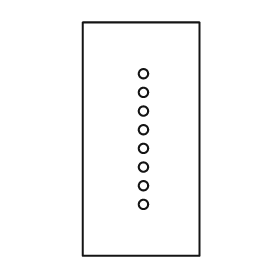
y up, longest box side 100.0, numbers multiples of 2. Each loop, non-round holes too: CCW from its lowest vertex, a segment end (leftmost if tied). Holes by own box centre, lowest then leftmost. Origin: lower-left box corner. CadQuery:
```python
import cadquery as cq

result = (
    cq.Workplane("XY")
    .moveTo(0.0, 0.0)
    .lineTo(50.0, 0.0)
    .lineTo(50.0, 100.0)
    .lineTo(0.0, 100.0)
    .close()
    .moveTo(26.0, 22.0)
    .circle(2.0)
    .moveTo(26.0, 30.0)
    .circle(2.0)
    .moveTo(26.0, 38.0)
    .circle(2.0)
    .moveTo(26.0, 46.0)
    .circle(2.0)
    .moveTo(26.0, 54.0)
    .circle(2.0)
    .moveTo(26.0, 62.0)
    .circle(2.0)
    .moveTo(26.0, 70.0)
    .circle(2.0)
    .moveTo(26.0, 78.0)
    .circle(2.0)
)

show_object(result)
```